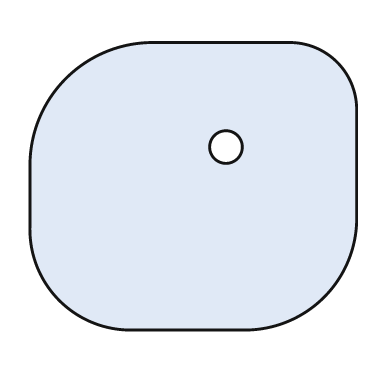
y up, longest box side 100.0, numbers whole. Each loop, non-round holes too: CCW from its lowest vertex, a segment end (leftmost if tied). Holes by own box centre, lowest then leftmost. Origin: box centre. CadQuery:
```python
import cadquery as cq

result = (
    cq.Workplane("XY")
    .moveTo(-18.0, -44.0)
    .lineTo(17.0, -44.0)
    .threePointArc((40.0, -34.0), (50.0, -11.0))
    .lineTo(50.0, 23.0)
    .threePointArc((44.0, 38.0), (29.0, 44.0))
    .lineTo(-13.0, 44.0)
    .threePointArc((-39.0, 33.0), (-50.0, 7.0))
    .lineTo(-50.0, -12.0)
    .threePointArc((-41.0, -35.0), (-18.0, -44.0))
    .close()
    .moveTo(10.0, 12.0)
    .circle(5.0)
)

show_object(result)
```